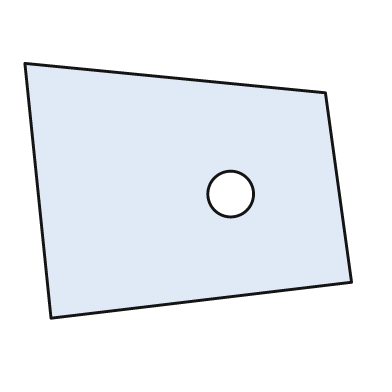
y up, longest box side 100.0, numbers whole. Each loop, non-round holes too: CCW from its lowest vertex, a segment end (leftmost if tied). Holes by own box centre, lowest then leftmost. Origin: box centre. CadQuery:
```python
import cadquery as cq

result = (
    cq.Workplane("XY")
    .moveTo(-42.0, -39.0)
    .lineTo(50.0, -28.0)
    .lineTo(42.0, 30.0)
    .lineTo(-50.0, 39.0)
    .close()
    .moveTo(13.0, -1.0)
    .circle(7.0)
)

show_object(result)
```